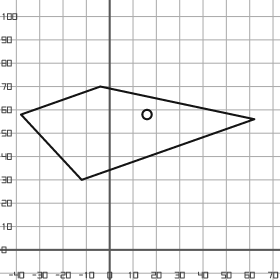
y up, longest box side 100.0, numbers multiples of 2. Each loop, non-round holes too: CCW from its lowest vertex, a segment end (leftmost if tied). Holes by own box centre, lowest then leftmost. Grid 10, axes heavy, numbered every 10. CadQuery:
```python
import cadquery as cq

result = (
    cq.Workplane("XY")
    .moveTo(-12.0, 30.0)
    .lineTo(62.0, 56.0)
    .lineTo(-4.0, 70.0)
    .lineTo(-38.0, 58.0)
    .close()
    .moveTo(16.0, 58.0)
    .circle(2.0)
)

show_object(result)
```